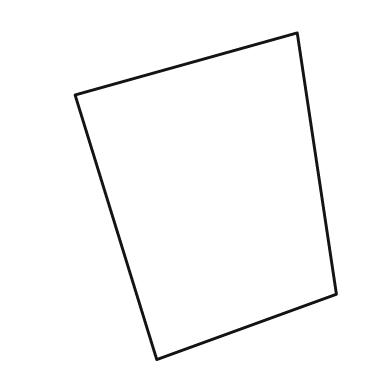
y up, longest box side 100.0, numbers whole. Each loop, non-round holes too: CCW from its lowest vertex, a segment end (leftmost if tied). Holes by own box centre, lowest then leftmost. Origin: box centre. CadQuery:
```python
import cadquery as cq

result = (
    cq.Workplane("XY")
    .moveTo(-15.0, -50.0)
    .lineTo(40.0, -30.0)
    .lineTo(28.0, 50.0)
    .lineTo(-40.0, 31.0)
    .close()
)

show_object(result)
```